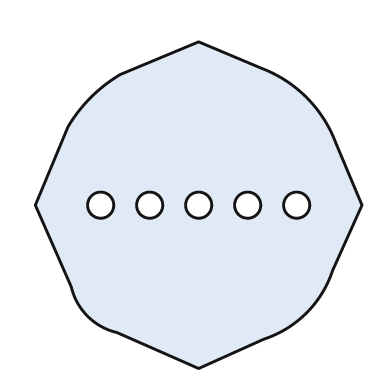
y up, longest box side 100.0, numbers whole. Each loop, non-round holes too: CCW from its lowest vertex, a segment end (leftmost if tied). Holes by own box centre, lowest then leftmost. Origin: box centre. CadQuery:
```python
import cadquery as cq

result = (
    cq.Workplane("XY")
    .moveTo(0.0, -50.0)
    .lineTo(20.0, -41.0)
    .threePointArc((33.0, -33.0), (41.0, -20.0))
    .lineTo(50.0, 0.0)
    .lineTo(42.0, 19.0)
    .threePointArc((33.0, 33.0), (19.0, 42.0))
    .lineTo(0.0, 50.0)
    .lineTo(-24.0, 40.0)
    .threePointArc((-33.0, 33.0), (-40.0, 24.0))
    .lineTo(-50.0, 0.0)
    .lineTo(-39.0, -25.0)
    .threePointArc((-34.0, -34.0), (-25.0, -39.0))
    .close()
    .moveTo(-30.0, 0.0)
    .circle(4.0)
    .moveTo(-15.0, 0.0)
    .circle(4.0)
    .moveTo(0.0, 0.0)
    .circle(4.0)
    .moveTo(15.0, 0.0)
    .circle(4.0)
    .moveTo(30.0, 0.0)
    .circle(4.0)
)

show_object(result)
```